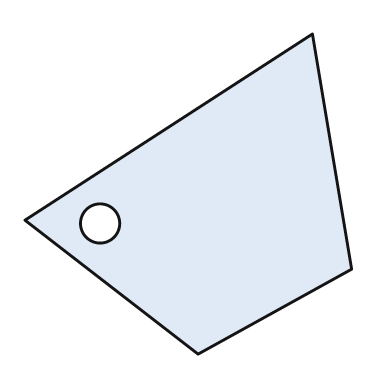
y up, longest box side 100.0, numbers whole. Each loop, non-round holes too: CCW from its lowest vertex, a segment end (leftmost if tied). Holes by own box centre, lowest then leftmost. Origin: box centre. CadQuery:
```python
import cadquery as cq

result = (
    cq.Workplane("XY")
    .moveTo(3.0, -49.0)
    .lineTo(50.0, -23.0)
    .lineTo(38.0, 49.0)
    .lineTo(-50.0, -8.0)
    .close()
    .moveTo(-27.0, -9.0)
    .circle(6.0)
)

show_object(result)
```